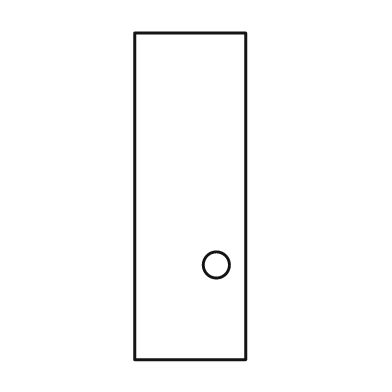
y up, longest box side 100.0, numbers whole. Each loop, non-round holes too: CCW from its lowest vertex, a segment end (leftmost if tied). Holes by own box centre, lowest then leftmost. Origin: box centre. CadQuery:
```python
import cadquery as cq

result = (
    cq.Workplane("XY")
    .moveTo(-17.0, -50.0)
    .lineTo(17.0, -50.0)
    .lineTo(17.0, 50.0)
    .lineTo(-17.0, 50.0)
    .close()
    .moveTo(8.0, -21.0)
    .circle(4.0)
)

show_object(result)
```